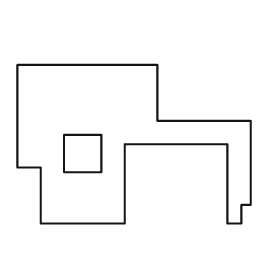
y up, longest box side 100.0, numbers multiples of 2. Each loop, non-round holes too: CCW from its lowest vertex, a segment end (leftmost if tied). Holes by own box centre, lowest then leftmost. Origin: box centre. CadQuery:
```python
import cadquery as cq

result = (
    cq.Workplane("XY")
    .moveTo(-40.0, -34.0)
    .lineTo(-4.0, -34.0)
    .lineTo(-4.0, 0.0)
    .lineTo(40.0, 0.0)
    .lineTo(40.0, -34.0)
    .lineTo(46.0, -34.0)
    .lineTo(46.0, -26.0)
    .lineTo(50.0, -26.0)
    .lineTo(50.0, 10.0)
    .lineTo(10.0, 10.0)
    .lineTo(10.0, 34.0)
    .lineTo(-50.0, 34.0)
    .lineTo(-50.0, -10.0)
    .lineTo(-40.0, -10.0)
    .close()
    .moveTo(-30.0, -12.0)
    .lineTo(-14.0, -12.0)
    .lineTo(-14.0, 4.0)
    .lineTo(-30.0, 4.0)
    .close()
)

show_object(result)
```